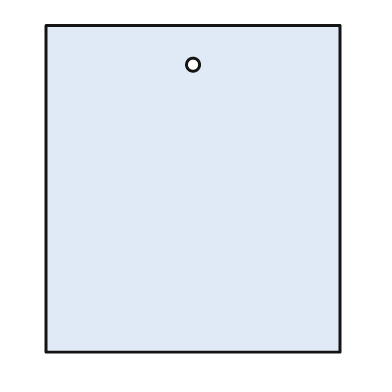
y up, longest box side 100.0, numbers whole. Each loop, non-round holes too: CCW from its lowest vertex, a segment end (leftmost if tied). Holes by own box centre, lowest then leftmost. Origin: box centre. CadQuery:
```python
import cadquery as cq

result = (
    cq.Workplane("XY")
    .moveTo(-45.0, -50.0)
    .lineTo(45.0, -50.0)
    .lineTo(45.0, 50.0)
    .lineTo(-45.0, 50.0)
    .close()
    .moveTo(0.0, 38.0)
    .circle(2.0)
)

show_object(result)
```